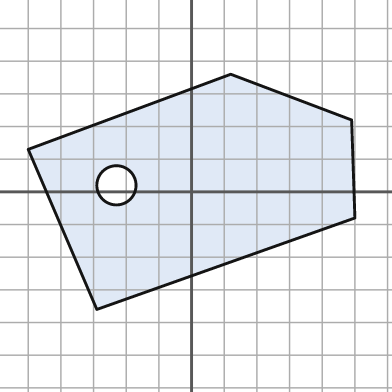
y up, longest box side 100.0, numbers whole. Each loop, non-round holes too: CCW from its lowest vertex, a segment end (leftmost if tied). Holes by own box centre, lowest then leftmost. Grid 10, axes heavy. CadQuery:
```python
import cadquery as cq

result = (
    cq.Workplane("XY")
    .moveTo(-29.0, -36.0)
    .lineTo(50.0, -8.0)
    .lineTo(49.0, 22.0)
    .lineTo(12.0, 36.0)
    .lineTo(-50.0, 13.0)
    .close()
    .moveTo(-23.0, 2.0)
    .circle(6.0)
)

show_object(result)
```